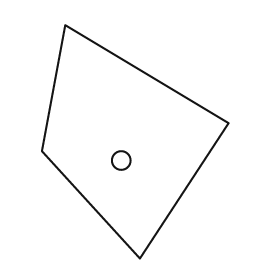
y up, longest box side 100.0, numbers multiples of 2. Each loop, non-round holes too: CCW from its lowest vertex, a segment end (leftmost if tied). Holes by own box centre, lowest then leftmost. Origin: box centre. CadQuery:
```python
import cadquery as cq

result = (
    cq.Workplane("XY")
    .moveTo(2.0, -50.0)
    .lineTo(40.0, 8.0)
    .lineTo(-30.0, 50.0)
    .lineTo(-40.0, -4.0)
    .close()
    .moveTo(-6.0, -8.0)
    .circle(4.0)
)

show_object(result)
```